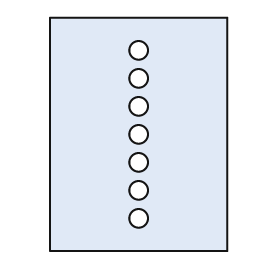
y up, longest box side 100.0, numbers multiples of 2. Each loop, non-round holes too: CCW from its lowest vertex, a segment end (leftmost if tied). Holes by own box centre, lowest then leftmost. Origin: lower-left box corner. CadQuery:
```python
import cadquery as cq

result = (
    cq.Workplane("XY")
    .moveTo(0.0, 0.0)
    .lineTo(76.0, 0.0)
    .lineTo(76.0, 100.0)
    .lineTo(0.0, 100.0)
    .close()
    .moveTo(38.0, 14.0)
    .circle(4.0)
    .moveTo(38.0, 26.0)
    .circle(4.0)
    .moveTo(38.0, 38.0)
    .circle(4.0)
    .moveTo(38.0, 50.0)
    .circle(4.0)
    .moveTo(38.0, 62.0)
    .circle(4.0)
    .moveTo(38.0, 74.0)
    .circle(4.0)
    .moveTo(38.0, 86.0)
    .circle(4.0)
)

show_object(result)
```